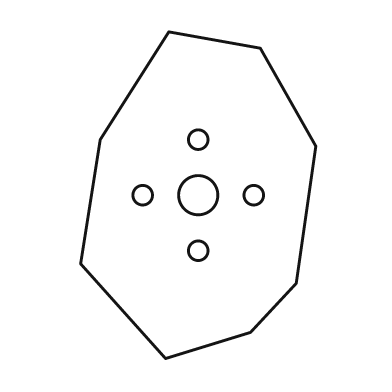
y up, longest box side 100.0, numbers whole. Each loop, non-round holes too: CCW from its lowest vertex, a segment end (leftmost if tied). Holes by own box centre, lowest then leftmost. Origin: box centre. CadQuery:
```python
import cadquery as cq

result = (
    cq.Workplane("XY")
    .moveTo(-10.0, -50.0)
    .lineTo(16.0, -42.0)
    .lineTo(30.0, -27.0)
    .lineTo(36.0, 15.0)
    .lineTo(19.0, 45.0)
    .lineTo(-9.0, 50.0)
    .lineTo(-30.0, 17.0)
    .lineTo(-36.0, -21.0)
    .close()
    .moveTo(0.0, -17.0)
    .circle(3.0)
    .moveTo(-17.0, 0.0)
    .circle(3.0)
    .moveTo(0.0, 0.0)
    .circle(6.0)
    .moveTo(17.0, 0.0)
    .circle(3.0)
    .moveTo(0.0, 17.0)
    .circle(3.0)
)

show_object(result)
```